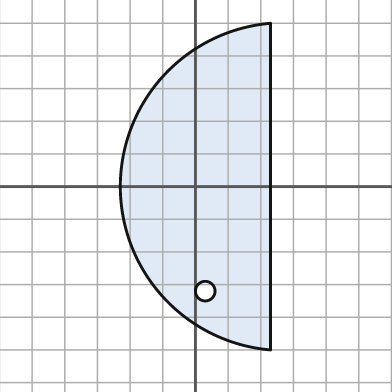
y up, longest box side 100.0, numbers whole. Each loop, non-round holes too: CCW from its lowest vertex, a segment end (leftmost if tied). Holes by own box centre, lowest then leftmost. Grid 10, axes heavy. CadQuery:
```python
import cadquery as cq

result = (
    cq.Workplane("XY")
    .moveTo(23.0, -50.0)
    .lineTo(23.0, 50.0)
    .threePointArc((-23.0, 0.0), (23.0, -50.0))
    .close()
    .moveTo(3.0, -32.0)
    .circle(3.0)
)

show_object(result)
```